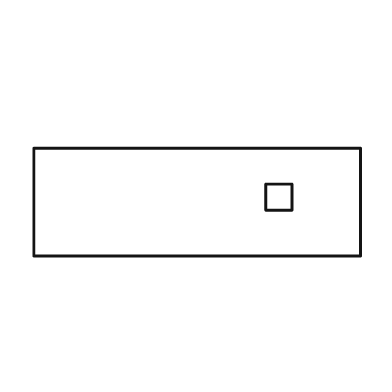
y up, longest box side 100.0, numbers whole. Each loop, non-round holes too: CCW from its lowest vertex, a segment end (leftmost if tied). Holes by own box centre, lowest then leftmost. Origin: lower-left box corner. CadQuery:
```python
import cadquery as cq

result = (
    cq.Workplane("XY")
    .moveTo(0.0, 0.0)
    .lineTo(100.0, 0.0)
    .lineTo(100.0, 33.0)
    .lineTo(0.0, 33.0)
    .close()
    .moveTo(71.0, 14.0)
    .lineTo(79.0, 14.0)
    .lineTo(79.0, 22.0)
    .lineTo(71.0, 22.0)
    .close()
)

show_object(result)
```